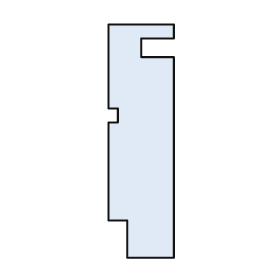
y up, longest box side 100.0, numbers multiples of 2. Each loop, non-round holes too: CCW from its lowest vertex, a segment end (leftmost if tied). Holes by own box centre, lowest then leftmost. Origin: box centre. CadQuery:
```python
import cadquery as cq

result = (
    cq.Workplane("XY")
    .moveTo(-6.0, -50.0)
    .lineTo(14.0, -50.0)
    .lineTo(14.0, 36.0)
    .lineTo(0.0, 36.0)
    .lineTo(0.0, 44.0)
    .lineTo(14.0, 44.0)
    .lineTo(14.0, 50.0)
    .lineTo(-14.0, 50.0)
    .lineTo(-14.0, 14.0)
    .lineTo(-10.0, 14.0)
    .lineTo(-10.0, 8.0)
    .lineTo(-14.0, 8.0)
    .lineTo(-14.0, -34.0)
    .lineTo(-6.0, -34.0)
    .close()
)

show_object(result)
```